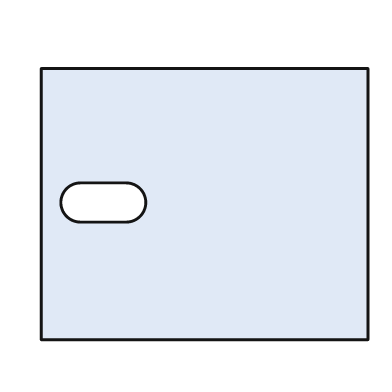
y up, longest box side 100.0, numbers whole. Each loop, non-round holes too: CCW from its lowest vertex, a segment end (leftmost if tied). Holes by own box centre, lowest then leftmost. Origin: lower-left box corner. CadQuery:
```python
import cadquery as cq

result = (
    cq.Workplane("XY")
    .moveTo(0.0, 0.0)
    .lineTo(100.0, 0.0)
    .lineTo(100.0, 83.0)
    .lineTo(0.0, 83.0)
    .close()
    .moveTo(12.0, 36.0)
    .lineTo(26.0, 36.0)
    .threePointArc((32.0, 42.0), (26.0, 48.0))
    .lineTo(12.0, 48.0)
    .threePointArc((6.0, 42.0), (12.0, 36.0))
    .close()
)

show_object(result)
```